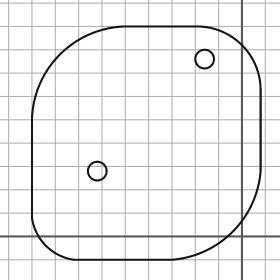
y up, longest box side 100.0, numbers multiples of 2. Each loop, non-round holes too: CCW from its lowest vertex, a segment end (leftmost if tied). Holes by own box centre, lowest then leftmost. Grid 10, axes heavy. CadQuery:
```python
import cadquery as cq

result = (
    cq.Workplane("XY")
    .moveTo(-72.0, -10.0)
    .lineTo(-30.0, -10.0)
    .threePointArc((-4.0, 2.0), (8.0, 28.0))
    .lineTo(8.0, 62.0)
    .threePointArc((0.0, 82.0), (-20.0, 90.0))
    .lineTo(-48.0, 90.0)
    .threePointArc((-78.0, 78.0), (-90.0, 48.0))
    .lineTo(-90.0, 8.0)
    .threePointArc((-84.0, -4.0), (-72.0, -10.0))
    .close()
    .moveTo(-62.0, 28.0)
    .circle(4.0)
    .moveTo(-16.0, 76.0)
    .circle(4.0)
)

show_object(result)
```